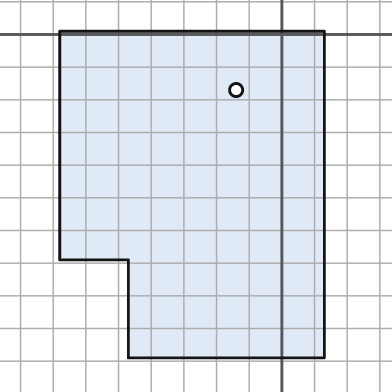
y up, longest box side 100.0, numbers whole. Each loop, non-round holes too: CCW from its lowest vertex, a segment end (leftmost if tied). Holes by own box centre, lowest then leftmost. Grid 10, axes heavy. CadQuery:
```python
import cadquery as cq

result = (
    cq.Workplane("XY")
    .moveTo(-47.0, -99.0)
    .lineTo(13.0, -99.0)
    .lineTo(13.0, 1.0)
    .lineTo(-68.0, 1.0)
    .lineTo(-68.0, -69.0)
    .lineTo(-47.0, -69.0)
    .close()
    .moveTo(-14.0, -17.0)
    .circle(2.0)
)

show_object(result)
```